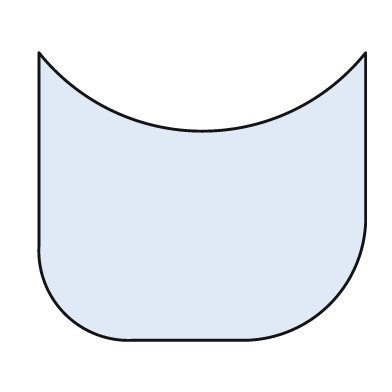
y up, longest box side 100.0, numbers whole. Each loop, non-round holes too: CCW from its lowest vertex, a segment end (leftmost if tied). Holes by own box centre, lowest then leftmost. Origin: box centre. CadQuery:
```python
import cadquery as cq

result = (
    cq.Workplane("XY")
    .moveTo(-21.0, -44.0)
    .lineTo(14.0, -44.0)
    .threePointArc((39.0, -33.0), (50.0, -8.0))
    .lineTo(50.0, 44.0)
    .threePointArc((0.0, 20.0), (-50.0, 44.0))
    .lineTo(-50.0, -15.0)
    .threePointArc((-42.0, -36.0), (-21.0, -44.0))
    .close()
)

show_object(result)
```